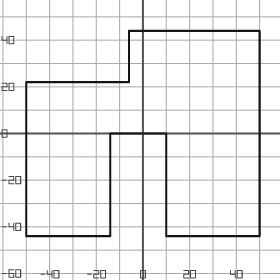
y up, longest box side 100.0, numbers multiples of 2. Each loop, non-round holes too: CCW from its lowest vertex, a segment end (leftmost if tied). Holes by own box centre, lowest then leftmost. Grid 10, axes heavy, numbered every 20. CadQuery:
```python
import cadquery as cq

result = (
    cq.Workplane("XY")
    .moveTo(-50.0, -44.0)
    .lineTo(-14.0, -44.0)
    .lineTo(-14.0, 0.0)
    .lineTo(10.0, 0.0)
    .lineTo(10.0, -44.0)
    .lineTo(50.0, -44.0)
    .lineTo(50.0, 44.0)
    .lineTo(-6.0, 44.0)
    .lineTo(-6.0, 22.0)
    .lineTo(-50.0, 22.0)
    .close()
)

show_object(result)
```